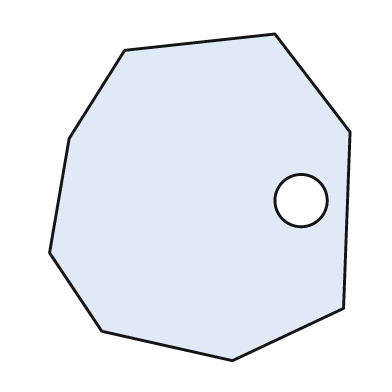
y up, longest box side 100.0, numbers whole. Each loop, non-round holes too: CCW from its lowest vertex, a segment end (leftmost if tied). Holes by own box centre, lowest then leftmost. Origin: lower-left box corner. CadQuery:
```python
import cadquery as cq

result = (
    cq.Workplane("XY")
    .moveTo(56.0, 0.0)
    .lineTo(90.0, 16.0)
    .lineTo(92.0, 70.0)
    .lineTo(69.0, 100.0)
    .lineTo(23.0, 95.0)
    .lineTo(6.0, 68.0)
    .lineTo(0.0, 33.0)
    .lineTo(16.0, 9.0)
    .close()
    .moveTo(77.0, 49.0)
    .circle(8.0)
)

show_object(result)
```